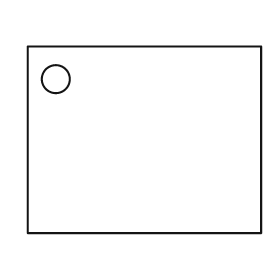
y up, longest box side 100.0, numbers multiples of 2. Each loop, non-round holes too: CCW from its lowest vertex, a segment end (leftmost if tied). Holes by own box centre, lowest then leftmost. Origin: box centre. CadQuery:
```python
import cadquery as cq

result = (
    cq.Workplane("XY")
    .moveTo(-50.0, -40.0)
    .lineTo(50.0, -40.0)
    .lineTo(50.0, 40.0)
    .lineTo(-50.0, 40.0)
    .close()
    .moveTo(-38.0, 26.0)
    .circle(6.0)
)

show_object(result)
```